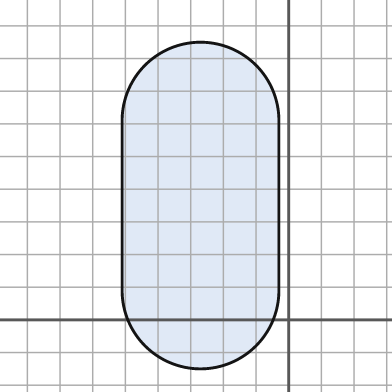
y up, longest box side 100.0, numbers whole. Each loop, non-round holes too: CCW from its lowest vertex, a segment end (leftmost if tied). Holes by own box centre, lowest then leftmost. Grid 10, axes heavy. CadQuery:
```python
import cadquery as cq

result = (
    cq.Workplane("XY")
    .moveTo(-51.0, 9.0)
    .threePointArc((-27.0, -15.0), (-3.0, 9.0))
    .lineTo(-3.0, 61.0)
    .threePointArc((-27.0, 85.0), (-51.0, 61.0))
    .close()
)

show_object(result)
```